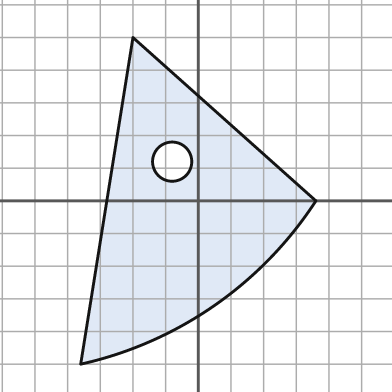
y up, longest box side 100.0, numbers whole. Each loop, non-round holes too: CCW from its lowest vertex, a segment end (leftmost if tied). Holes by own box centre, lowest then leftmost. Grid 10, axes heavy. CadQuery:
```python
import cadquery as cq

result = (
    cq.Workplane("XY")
    .moveTo(-36.0, -50.0)
    .threePointArc((5.0, -32.0), (36.0, 0.0))
    .lineTo(-20.0, 50.0)
    .close()
    .moveTo(-8.0, 12.0)
    .circle(6.0)
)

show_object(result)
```